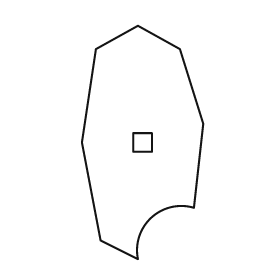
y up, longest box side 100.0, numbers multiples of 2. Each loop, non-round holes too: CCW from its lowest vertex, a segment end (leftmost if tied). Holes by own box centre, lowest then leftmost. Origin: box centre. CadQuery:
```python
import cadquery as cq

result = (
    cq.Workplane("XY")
    .moveTo(-2.0, -50.0)
    .threePointArc((4.0, -32.0), (22.0, -28.0))
    .lineTo(26.0, 8.0)
    .lineTo(16.0, 40.0)
    .lineTo(-2.0, 50.0)
    .lineTo(-20.0, 40.0)
    .lineTo(-26.0, 0.0)
    .lineTo(-18.0, -42.0)
    .close()
    .moveTo(-4.0, -4.0)
    .lineTo(4.0, -4.0)
    .lineTo(4.0, 4.0)
    .lineTo(-4.0, 4.0)
    .close()
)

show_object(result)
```